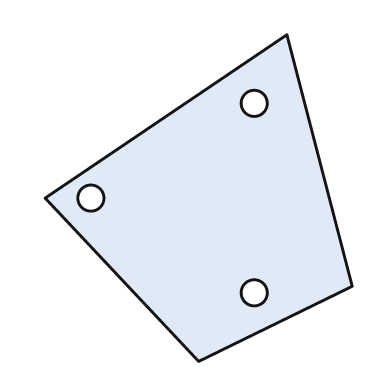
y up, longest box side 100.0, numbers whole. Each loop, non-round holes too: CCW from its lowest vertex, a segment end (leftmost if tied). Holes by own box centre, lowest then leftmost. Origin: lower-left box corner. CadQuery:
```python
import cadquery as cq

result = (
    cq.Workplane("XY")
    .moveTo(47.0, 0.0)
    .lineTo(94.0, 23.0)
    .lineTo(74.0, 100.0)
    .lineTo(0.0, 50.0)
    .close()
    .moveTo(64.0, 21.0)
    .circle(4.0)
    .moveTo(14.0, 50.0)
    .circle(4.0)
    .moveTo(64.0, 79.0)
    .circle(4.0)
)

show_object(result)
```